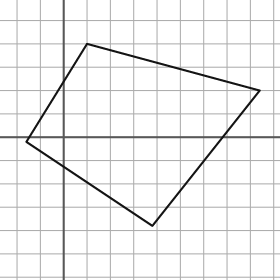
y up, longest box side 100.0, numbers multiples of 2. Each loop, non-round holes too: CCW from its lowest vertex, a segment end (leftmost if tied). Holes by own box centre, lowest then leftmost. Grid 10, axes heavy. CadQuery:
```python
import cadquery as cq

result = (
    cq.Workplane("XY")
    .moveTo(38.0, -38.0)
    .lineTo(84.0, 20.0)
    .lineTo(10.0, 40.0)
    .lineTo(-16.0, -2.0)
    .close()
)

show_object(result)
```